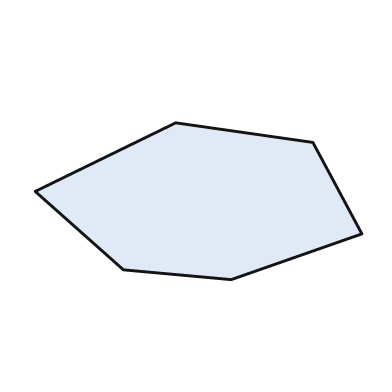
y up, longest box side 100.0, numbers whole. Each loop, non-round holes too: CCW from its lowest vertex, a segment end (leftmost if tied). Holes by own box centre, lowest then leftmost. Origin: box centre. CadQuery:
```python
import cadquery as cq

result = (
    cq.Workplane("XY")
    .moveTo(10.0, -24.0)
    .lineTo(50.0, -10.0)
    .lineTo(35.0, 18.0)
    .lineTo(-7.0, 24.0)
    .lineTo(-50.0, 3.0)
    .lineTo(-23.0, -21.0)
    .close()
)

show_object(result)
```